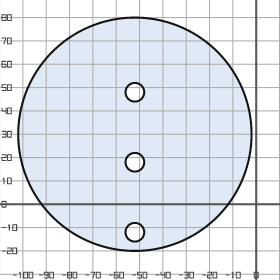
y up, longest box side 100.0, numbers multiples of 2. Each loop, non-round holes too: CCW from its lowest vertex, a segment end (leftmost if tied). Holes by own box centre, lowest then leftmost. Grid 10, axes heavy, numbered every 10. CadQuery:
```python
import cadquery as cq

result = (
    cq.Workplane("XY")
    .moveTo(-52.0, 30.0)
    .circle(50.0)
    .moveTo(-52.0, -12.0)
    .circle(4.0)
    .moveTo(-52.0, 18.0)
    .circle(4.0)
    .moveTo(-52.0, 48.0)
    .circle(4.0)
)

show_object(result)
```